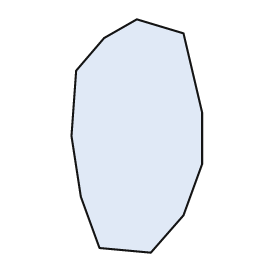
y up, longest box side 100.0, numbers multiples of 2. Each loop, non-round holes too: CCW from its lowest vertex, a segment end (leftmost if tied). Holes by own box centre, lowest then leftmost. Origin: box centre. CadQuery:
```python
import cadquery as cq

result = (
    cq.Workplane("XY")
    .moveTo(6.0, -50.0)
    .lineTo(20.0, -34.0)
    .lineTo(28.0, -12.0)
    .lineTo(28.0, 10.0)
    .lineTo(20.0, 44.0)
    .lineTo(0.0, 50.0)
    .lineTo(-14.0, 42.0)
    .lineTo(-26.0, 28.0)
    .lineTo(-28.0, 0.0)
    .lineTo(-24.0, -26.0)
    .lineTo(-16.0, -48.0)
    .close()
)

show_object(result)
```